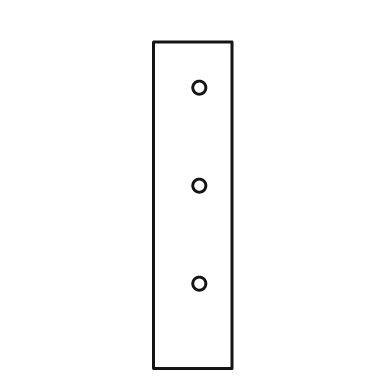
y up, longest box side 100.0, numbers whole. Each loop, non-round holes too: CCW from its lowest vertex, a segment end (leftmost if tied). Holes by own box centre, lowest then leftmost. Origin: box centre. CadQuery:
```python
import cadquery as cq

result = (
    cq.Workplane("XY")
    .moveTo(-12.0, -50.0)
    .lineTo(12.0, -50.0)
    .lineTo(12.0, 50.0)
    .lineTo(-12.0, 50.0)
    .close()
    .moveTo(2.0, -24.0)
    .circle(2.0)
    .moveTo(2.0, 6.0)
    .circle(2.0)
    .moveTo(2.0, 36.0)
    .circle(2.0)
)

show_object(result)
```